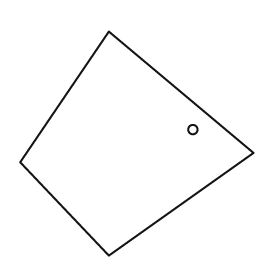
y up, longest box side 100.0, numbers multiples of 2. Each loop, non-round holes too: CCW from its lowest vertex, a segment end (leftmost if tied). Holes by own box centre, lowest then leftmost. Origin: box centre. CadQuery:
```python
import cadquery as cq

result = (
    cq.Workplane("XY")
    .moveTo(-12.0, -48.0)
    .lineTo(50.0, -4.0)
    .lineTo(-12.0, 48.0)
    .lineTo(-50.0, -8.0)
    .close()
    .moveTo(24.0, 6.0)
    .circle(2.0)
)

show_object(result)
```